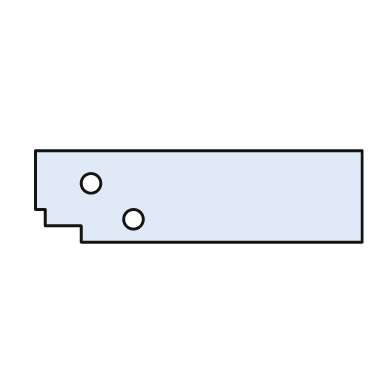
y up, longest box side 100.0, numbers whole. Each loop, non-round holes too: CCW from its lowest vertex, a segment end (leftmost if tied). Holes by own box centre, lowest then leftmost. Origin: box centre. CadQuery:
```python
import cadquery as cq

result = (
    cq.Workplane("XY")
    .moveTo(-36.0, -14.0)
    .lineTo(50.0, -14.0)
    .lineTo(50.0, 14.0)
    .lineTo(-50.0, 14.0)
    .lineTo(-50.0, -4.0)
    .lineTo(-47.0, -4.0)
    .lineTo(-47.0, -9.0)
    .lineTo(-36.0, -9.0)
    .close()
    .moveTo(-20.0, -7.0)
    .circle(3.0)
    .moveTo(-33.0, 4.0)
    .circle(3.0)
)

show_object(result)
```